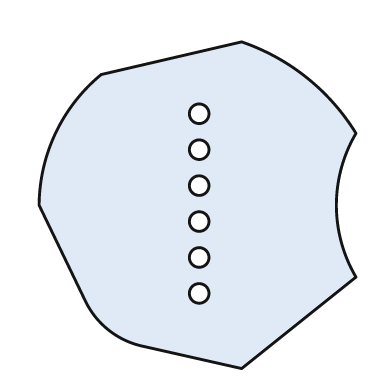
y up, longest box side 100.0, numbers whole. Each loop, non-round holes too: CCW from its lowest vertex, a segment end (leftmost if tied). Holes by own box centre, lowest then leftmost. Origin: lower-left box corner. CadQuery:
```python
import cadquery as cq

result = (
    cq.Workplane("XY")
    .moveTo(62.0, 0.0)
    .lineTo(97.0, 28.0)
    .threePointArc((91.0, 50.0), (97.0, 72.0))
    .threePointArc((82.0, 89.0), (62.0, 100.0))
    .lineTo(19.0, 90.0)
    .threePointArc((5.0, 72.0), (0.0, 50.0))
    .lineTo(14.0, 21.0)
    .threePointArc((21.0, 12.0), (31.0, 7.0))
    .close()
    .moveTo(49.0, 23.0)
    .circle(3.0)
    .moveTo(49.0, 34.0)
    .circle(3.0)
    .moveTo(49.0, 45.0)
    .circle(3.0)
    .moveTo(49.0, 56.0)
    .circle(3.0)
    .moveTo(49.0, 67.0)
    .circle(3.0)
    .moveTo(49.0, 78.0)
    .circle(3.0)
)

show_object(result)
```